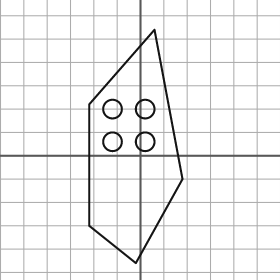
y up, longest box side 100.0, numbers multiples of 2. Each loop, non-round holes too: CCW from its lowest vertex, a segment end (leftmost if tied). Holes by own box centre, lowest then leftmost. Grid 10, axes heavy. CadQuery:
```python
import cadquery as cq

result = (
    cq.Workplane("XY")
    .moveTo(-2.0, -46.0)
    .lineTo(18.0, -10.0)
    .lineTo(6.0, 54.0)
    .lineTo(-22.0, 22.0)
    .lineTo(-22.0, -30.0)
    .close()
    .moveTo(-12.0, 6.0)
    .circle(4.0)
    .moveTo(2.0, 6.0)
    .circle(4.0)
    .moveTo(-12.0, 20.0)
    .circle(4.0)
    .moveTo(2.0, 20.0)
    .circle(4.0)
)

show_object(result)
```